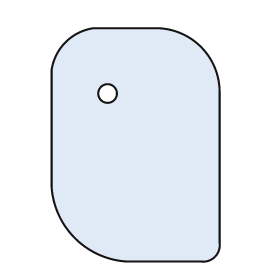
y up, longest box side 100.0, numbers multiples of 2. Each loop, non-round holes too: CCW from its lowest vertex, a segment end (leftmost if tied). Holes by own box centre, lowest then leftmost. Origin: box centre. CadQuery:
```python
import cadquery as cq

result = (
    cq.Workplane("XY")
    .moveTo(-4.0, -50.0)
    .lineTo(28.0, -50.0)
    .threePointArc((34.0, -48.0), (36.0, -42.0))
    .lineTo(36.0, 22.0)
    .threePointArc((28.0, 42.0), (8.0, 50.0))
    .lineTo(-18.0, 50.0)
    .threePointArc((-30.0, 44.0), (-36.0, 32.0))
    .lineTo(-36.0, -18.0)
    .threePointArc((-26.0, -40.0), (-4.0, -50.0))
    .close()
    .moveTo(-12.0, 22.0)
    .circle(4.0)
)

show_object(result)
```